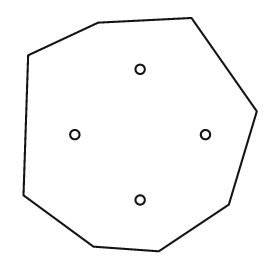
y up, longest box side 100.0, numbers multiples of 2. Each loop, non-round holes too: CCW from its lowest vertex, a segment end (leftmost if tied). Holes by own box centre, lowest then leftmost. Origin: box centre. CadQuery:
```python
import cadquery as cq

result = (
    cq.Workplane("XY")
    .moveTo(8.0, -50.0)
    .lineTo(38.0, -30.0)
    .lineTo(50.0, 10.0)
    .lineTo(22.0, 50.0)
    .lineTo(-18.0, 48.0)
    .lineTo(-48.0, 34.0)
    .lineTo(-50.0, -26.0)
    .lineTo(-20.0, -48.0)
    .close()
    .moveTo(0.0, -28.0)
    .circle(2.0)
    .moveTo(-28.0, 0.0)
    .circle(2.0)
    .moveTo(28.0, 0.0)
    .circle(2.0)
    .moveTo(0.0, 28.0)
    .circle(2.0)
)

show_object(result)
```